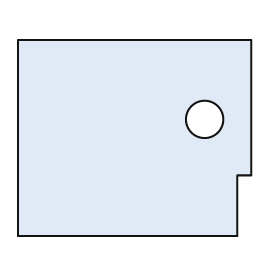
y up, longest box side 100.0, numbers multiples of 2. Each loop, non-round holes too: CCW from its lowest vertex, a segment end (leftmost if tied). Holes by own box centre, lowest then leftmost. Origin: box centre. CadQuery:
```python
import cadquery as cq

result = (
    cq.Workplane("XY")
    .moveTo(-50.0, -42.0)
    .lineTo(44.0, -42.0)
    .lineTo(44.0, -16.0)
    .lineTo(50.0, -16.0)
    .lineTo(50.0, 42.0)
    .lineTo(-50.0, 42.0)
    .close()
    .moveTo(30.0, 8.0)
    .circle(8.0)
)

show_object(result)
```